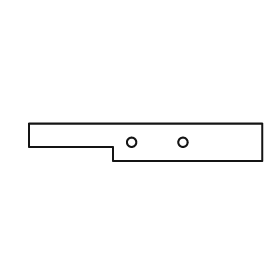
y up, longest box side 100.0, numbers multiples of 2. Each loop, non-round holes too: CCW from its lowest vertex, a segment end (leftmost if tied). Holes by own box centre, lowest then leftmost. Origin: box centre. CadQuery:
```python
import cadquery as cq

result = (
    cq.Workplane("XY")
    .moveTo(-14.0, -8.0)
    .lineTo(50.0, -8.0)
    .lineTo(50.0, 8.0)
    .lineTo(-50.0, 8.0)
    .lineTo(-50.0, -2.0)
    .lineTo(-14.0, -2.0)
    .close()
    .moveTo(-6.0, 0.0)
    .circle(2.0)
    .moveTo(16.0, 0.0)
    .circle(2.0)
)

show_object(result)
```